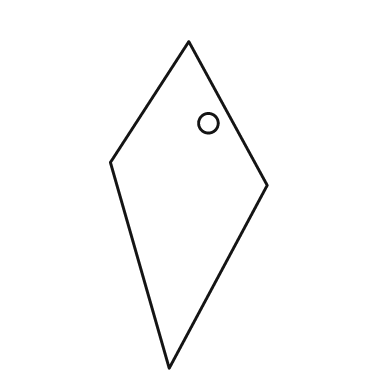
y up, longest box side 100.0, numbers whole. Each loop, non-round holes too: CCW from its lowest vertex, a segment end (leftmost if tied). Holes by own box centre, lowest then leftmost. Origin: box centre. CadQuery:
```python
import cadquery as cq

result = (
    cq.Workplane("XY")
    .moveTo(-6.0, -50.0)
    .lineTo(24.0, 6.0)
    .lineTo(0.0, 50.0)
    .lineTo(-24.0, 13.0)
    .close()
    .moveTo(6.0, 25.0)
    .circle(3.0)
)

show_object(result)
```